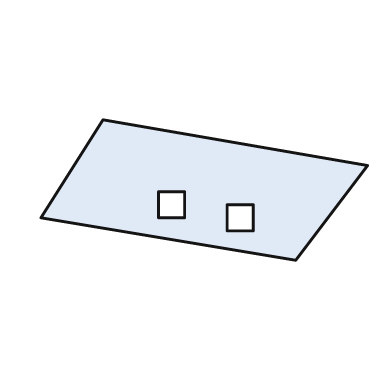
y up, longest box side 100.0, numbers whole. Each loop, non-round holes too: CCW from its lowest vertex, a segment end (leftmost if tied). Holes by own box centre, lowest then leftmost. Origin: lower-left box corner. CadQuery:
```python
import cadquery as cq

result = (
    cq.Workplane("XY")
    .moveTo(78.0, 0.0)
    .lineTo(100.0, 29.0)
    .lineTo(19.0, 43.0)
    .lineTo(0.0, 13.0)
    .close()
    .moveTo(57.0, 9.0)
    .lineTo(65.0, 9.0)
    .lineTo(65.0, 17.0)
    .lineTo(57.0, 17.0)
    .close()
    .moveTo(36.0, 13.0)
    .lineTo(44.0, 13.0)
    .lineTo(44.0, 21.0)
    .lineTo(36.0, 21.0)
    .close()
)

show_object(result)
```